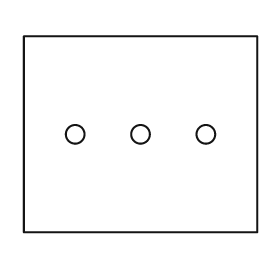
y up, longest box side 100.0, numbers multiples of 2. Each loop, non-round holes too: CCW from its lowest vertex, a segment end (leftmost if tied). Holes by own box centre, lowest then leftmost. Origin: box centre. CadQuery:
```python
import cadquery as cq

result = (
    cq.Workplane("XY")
    .moveTo(-50.0, -42.0)
    .lineTo(50.0, -42.0)
    .lineTo(50.0, 42.0)
    .lineTo(-50.0, 42.0)
    .close()
    .moveTo(-28.0, 0.0)
    .circle(4.0)
    .moveTo(0.0, 0.0)
    .circle(4.0)
    .moveTo(28.0, 0.0)
    .circle(4.0)
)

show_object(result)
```